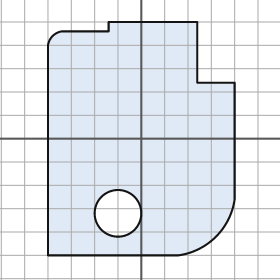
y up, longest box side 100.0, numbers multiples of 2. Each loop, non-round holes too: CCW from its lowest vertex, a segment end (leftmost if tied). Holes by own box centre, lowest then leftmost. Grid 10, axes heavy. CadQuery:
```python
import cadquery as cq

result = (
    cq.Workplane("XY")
    .moveTo(-40.0, -50.0)
    .lineTo(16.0, -50.0)
    .threePointArc((32.0, -42.0), (40.0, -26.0))
    .lineTo(40.0, 24.0)
    .lineTo(24.0, 24.0)
    .lineTo(24.0, 50.0)
    .lineTo(-14.0, 50.0)
    .lineTo(-14.0, 46.0)
    .lineTo(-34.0, 46.0)
    .threePointArc((-38.0, 44.0), (-40.0, 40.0))
    .close()
    .moveTo(-10.0, -32.0)
    .circle(10.0)
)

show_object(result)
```